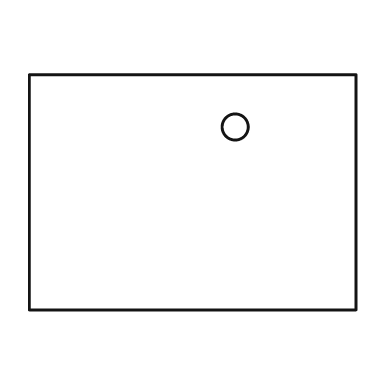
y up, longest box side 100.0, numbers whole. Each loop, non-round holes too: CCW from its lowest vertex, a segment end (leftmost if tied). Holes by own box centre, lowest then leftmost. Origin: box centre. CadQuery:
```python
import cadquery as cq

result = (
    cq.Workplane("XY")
    .moveTo(-50.0, -36.0)
    .lineTo(50.0, -36.0)
    .lineTo(50.0, 36.0)
    .lineTo(-50.0, 36.0)
    .close()
    .moveTo(13.0, 20.0)
    .circle(4.0)
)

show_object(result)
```